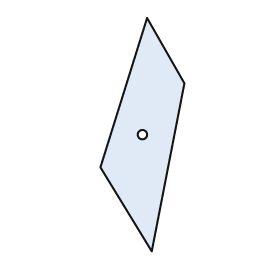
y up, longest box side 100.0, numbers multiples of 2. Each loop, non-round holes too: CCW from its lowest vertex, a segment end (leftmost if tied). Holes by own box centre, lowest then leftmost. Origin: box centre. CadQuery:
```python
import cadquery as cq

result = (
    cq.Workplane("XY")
    .moveTo(4.0, -50.0)
    .lineTo(18.0, 22.0)
    .lineTo(2.0, 50.0)
    .lineTo(-18.0, -14.0)
    .close()
    .moveTo(0.0, 0.0)
    .circle(2.0)
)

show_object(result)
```